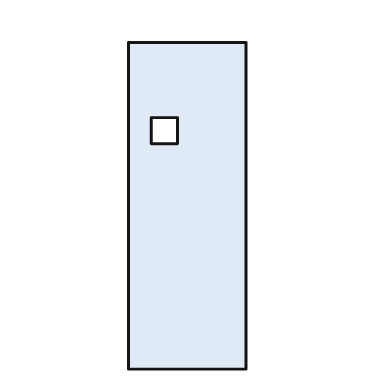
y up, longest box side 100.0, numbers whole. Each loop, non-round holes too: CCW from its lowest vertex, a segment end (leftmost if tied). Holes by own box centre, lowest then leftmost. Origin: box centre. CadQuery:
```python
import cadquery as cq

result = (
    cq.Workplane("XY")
    .moveTo(-18.0, -50.0)
    .lineTo(18.0, -50.0)
    .lineTo(18.0, 50.0)
    .lineTo(-18.0, 50.0)
    .close()
    .moveTo(-11.0, 19.0)
    .lineTo(-3.0, 19.0)
    .lineTo(-3.0, 27.0)
    .lineTo(-11.0, 27.0)
    .close()
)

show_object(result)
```